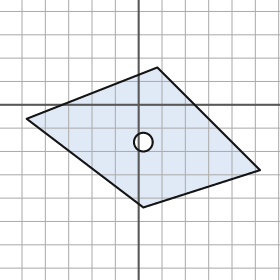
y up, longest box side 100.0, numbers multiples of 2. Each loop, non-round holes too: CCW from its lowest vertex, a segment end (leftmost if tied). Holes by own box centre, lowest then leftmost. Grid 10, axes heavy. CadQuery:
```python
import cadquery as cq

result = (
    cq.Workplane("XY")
    .moveTo(2.0, -44.0)
    .lineTo(52.0, -28.0)
    .lineTo(8.0, 16.0)
    .lineTo(-48.0, -6.0)
    .close()
    .moveTo(2.0, -16.0)
    .circle(4.0)
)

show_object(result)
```